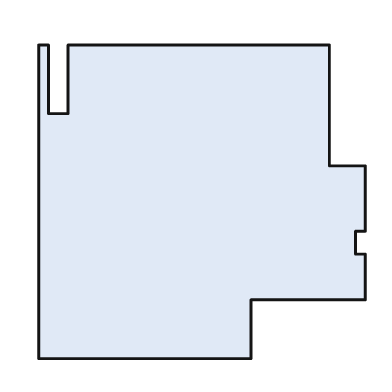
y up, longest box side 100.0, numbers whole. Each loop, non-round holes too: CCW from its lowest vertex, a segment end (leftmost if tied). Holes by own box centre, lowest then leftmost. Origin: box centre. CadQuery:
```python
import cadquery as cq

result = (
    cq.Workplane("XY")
    .moveTo(-50.0, -48.0)
    .lineTo(15.0, -48.0)
    .lineTo(15.0, -30.0)
    .lineTo(50.0, -30.0)
    .lineTo(50.0, -16.0)
    .lineTo(47.0, -16.0)
    .lineTo(47.0, -9.0)
    .lineTo(50.0, -9.0)
    .lineTo(50.0, 11.0)
    .lineTo(39.0, 11.0)
    .lineTo(39.0, 48.0)
    .lineTo(-41.0, 48.0)
    .lineTo(-41.0, 27.0)
    .lineTo(-47.0, 27.0)
    .lineTo(-47.0, 48.0)
    .lineTo(-50.0, 48.0)
    .close()
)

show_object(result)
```